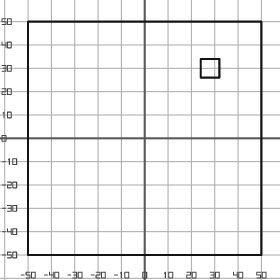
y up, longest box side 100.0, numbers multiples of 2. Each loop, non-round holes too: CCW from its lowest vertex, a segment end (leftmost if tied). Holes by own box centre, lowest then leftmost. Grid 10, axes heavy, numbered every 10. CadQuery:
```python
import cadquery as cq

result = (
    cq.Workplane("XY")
    .moveTo(-50.0, -50.0)
    .lineTo(50.0, -50.0)
    .lineTo(50.0, 50.0)
    .lineTo(-50.0, 50.0)
    .close()
    .moveTo(24.0, 26.0)
    .lineTo(32.0, 26.0)
    .lineTo(32.0, 34.0)
    .lineTo(24.0, 34.0)
    .close()
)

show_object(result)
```